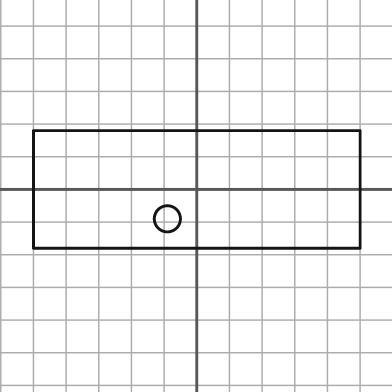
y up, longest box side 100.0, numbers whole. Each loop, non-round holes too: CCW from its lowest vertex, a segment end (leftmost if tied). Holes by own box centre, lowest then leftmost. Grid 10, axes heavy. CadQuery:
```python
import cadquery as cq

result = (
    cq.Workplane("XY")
    .moveTo(-50.0, -18.0)
    .lineTo(50.0, -18.0)
    .lineTo(50.0, 18.0)
    .lineTo(-50.0, 18.0)
    .close()
    .moveTo(-9.0, -9.0)
    .circle(4.0)
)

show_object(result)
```